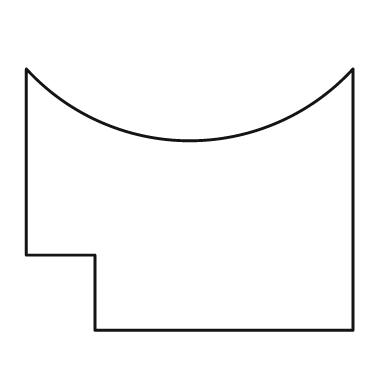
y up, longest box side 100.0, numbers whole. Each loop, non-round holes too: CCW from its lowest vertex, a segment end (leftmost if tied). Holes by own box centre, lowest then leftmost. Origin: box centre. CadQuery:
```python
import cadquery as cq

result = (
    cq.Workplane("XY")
    .moveTo(-29.0, -40.0)
    .lineTo(50.0, -40.0)
    .lineTo(50.0, 40.0)
    .threePointArc((0.0, 18.0), (-50.0, 40.0))
    .lineTo(-50.0, -17.0)
    .lineTo(-29.0, -17.0)
    .close()
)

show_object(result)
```